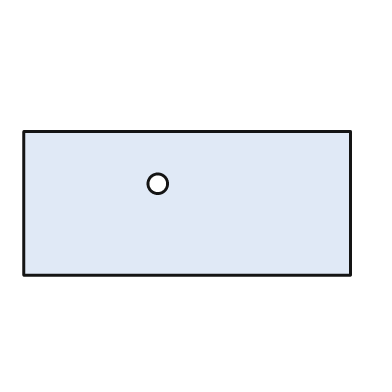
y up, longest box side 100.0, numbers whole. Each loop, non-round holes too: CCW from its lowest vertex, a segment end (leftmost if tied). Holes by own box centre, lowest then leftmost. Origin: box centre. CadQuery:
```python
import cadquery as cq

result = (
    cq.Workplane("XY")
    .moveTo(-50.0, -22.0)
    .lineTo(50.0, -22.0)
    .lineTo(50.0, 22.0)
    .lineTo(-50.0, 22.0)
    .close()
    .moveTo(-9.0, 6.0)
    .circle(3.0)
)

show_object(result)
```